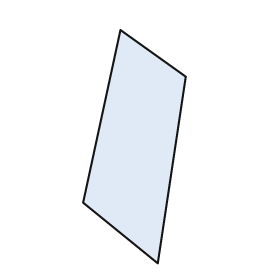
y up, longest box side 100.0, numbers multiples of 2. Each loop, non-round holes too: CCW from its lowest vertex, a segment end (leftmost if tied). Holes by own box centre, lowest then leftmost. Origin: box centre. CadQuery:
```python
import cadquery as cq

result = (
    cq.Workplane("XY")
    .moveTo(10.0, -50.0)
    .lineTo(22.0, 30.0)
    .lineTo(-6.0, 50.0)
    .lineTo(-22.0, -24.0)
    .close()
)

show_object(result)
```